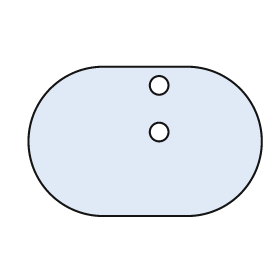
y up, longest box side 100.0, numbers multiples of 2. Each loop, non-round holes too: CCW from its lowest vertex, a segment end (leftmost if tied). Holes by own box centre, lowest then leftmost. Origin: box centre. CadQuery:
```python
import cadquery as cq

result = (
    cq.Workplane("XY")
    .moveTo(-18.0, -32.0)
    .lineTo(18.0, -32.0)
    .threePointArc((50.0, 0.0), (18.0, 32.0))
    .lineTo(-18.0, 32.0)
    .threePointArc((-50.0, 0.0), (-18.0, -32.0))
    .close()
    .moveTo(6.0, 4.0)
    .circle(4.0)
    .moveTo(6.0, 24.0)
    .circle(4.0)
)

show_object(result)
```